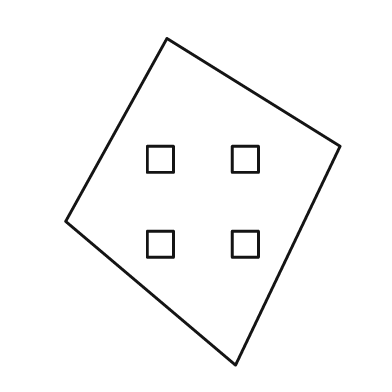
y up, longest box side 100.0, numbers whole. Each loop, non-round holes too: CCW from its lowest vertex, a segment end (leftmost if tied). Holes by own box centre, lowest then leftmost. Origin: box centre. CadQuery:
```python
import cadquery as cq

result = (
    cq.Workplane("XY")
    .moveTo(10.0, -50.0)
    .lineTo(42.0, 17.0)
    .lineTo(-11.0, 50.0)
    .lineTo(-42.0, -6.0)
    .close()
    .moveTo(-17.0, -17.0)
    .lineTo(-9.0, -17.0)
    .lineTo(-9.0, -9.0)
    .lineTo(-17.0, -9.0)
    .close()
    .moveTo(9.0, -17.0)
    .lineTo(17.0, -17.0)
    .lineTo(17.0, -9.0)
    .lineTo(9.0, -9.0)
    .close()
    .moveTo(-17.0, 9.0)
    .lineTo(-9.0, 9.0)
    .lineTo(-9.0, 17.0)
    .lineTo(-17.0, 17.0)
    .close()
    .moveTo(9.0, 9.0)
    .lineTo(17.0, 9.0)
    .lineTo(17.0, 17.0)
    .lineTo(9.0, 17.0)
    .close()
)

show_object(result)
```